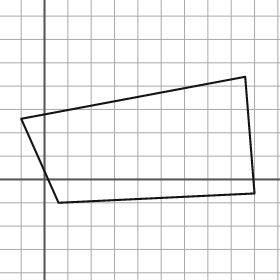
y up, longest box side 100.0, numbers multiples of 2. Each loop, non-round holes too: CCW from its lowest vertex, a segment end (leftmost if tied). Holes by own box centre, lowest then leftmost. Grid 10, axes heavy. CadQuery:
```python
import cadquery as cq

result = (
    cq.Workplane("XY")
    .moveTo(6.0, -10.0)
    .lineTo(90.0, -6.0)
    .lineTo(86.0, 44.0)
    .lineTo(-10.0, 26.0)
    .close()
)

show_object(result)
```